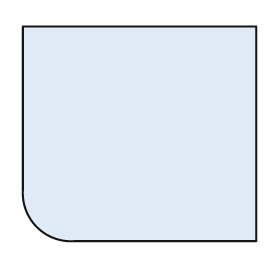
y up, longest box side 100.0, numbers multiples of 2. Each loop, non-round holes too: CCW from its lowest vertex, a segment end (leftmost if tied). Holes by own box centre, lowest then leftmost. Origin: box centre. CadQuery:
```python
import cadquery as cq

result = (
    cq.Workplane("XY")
    .moveTo(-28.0, -46.0)
    .lineTo(50.0, -46.0)
    .lineTo(50.0, 46.0)
    .lineTo(-50.0, 46.0)
    .lineTo(-50.0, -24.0)
    .threePointArc((-44.0, -40.0), (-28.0, -46.0))
    .close()
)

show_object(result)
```